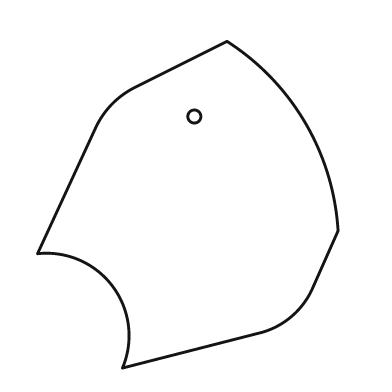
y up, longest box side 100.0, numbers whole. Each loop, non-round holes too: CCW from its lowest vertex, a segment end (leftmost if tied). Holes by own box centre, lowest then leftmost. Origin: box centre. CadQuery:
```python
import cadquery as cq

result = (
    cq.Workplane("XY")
    .moveTo(-20.0, -50.0)
    .lineTo(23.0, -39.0)
    .threePointArc((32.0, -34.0), (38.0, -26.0))
    .lineTo(46.0, -8.0)
    .threePointArc((36.0, 25.0), (12.0, 50.0))
    .lineTo(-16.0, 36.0)
    .threePointArc((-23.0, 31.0), (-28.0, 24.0))
    .lineTo(-46.0, -15.0)
    .threePointArc((-23.0, -25.0), (-20.0, -50.0))
    .close()
    .moveTo(2.0, 27.0)
    .circle(2.0)
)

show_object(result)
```